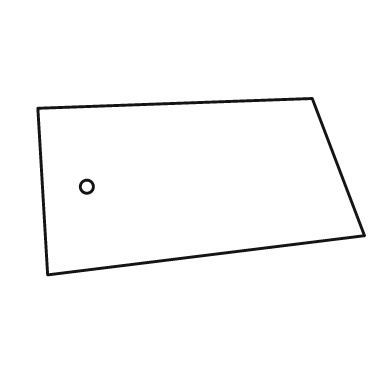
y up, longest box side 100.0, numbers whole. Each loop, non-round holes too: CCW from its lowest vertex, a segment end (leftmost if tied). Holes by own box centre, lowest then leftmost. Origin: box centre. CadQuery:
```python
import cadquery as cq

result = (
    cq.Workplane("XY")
    .moveTo(-47.0, -27.0)
    .lineTo(50.0, -15.0)
    .lineTo(34.0, 27.0)
    .lineTo(-50.0, 24.0)
    .close()
    .moveTo(-35.0, 0.0)
    .circle(2.0)
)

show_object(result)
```